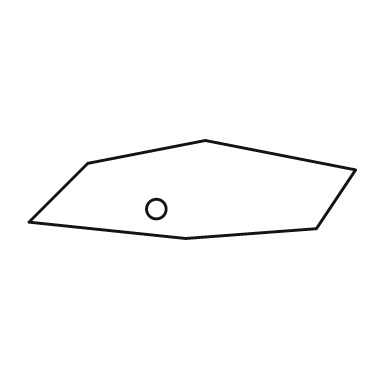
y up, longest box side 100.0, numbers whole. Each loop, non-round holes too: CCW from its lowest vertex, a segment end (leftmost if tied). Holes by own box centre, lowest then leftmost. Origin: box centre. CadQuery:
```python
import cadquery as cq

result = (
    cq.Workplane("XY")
    .moveTo(-2.0, -15.0)
    .lineTo(38.0, -12.0)
    .lineTo(50.0, 6.0)
    .lineTo(4.0, 15.0)
    .lineTo(-32.0, 8.0)
    .lineTo(-50.0, -10.0)
    .close()
    .moveTo(-11.0, -6.0)
    .circle(3.0)
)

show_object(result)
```